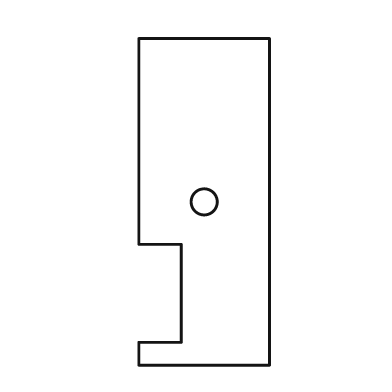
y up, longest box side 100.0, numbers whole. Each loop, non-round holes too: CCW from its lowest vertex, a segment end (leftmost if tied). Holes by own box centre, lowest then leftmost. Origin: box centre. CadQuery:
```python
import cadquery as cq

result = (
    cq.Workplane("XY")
    .moveTo(-20.0, -50.0)
    .lineTo(20.0, -50.0)
    .lineTo(20.0, 50.0)
    .lineTo(-20.0, 50.0)
    .lineTo(-20.0, -13.0)
    .lineTo(-7.0, -13.0)
    .lineTo(-7.0, -43.0)
    .lineTo(-20.0, -43.0)
    .close()
    .moveTo(0.0, 0.0)
    .circle(4.0)
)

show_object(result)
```